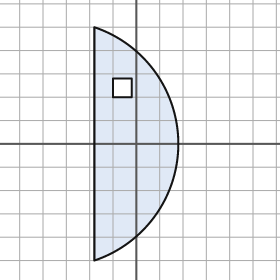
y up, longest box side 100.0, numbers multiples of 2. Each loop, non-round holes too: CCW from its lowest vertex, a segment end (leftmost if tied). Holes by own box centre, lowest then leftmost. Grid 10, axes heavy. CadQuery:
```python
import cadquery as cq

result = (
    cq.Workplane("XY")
    .moveTo(-18.0, -50.0)
    .threePointArc((18.0, 0.0), (-18.0, 50.0))
    .close()
    .moveTo(-10.0, 20.0)
    .lineTo(-2.0, 20.0)
    .lineTo(-2.0, 28.0)
    .lineTo(-10.0, 28.0)
    .close()
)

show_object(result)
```